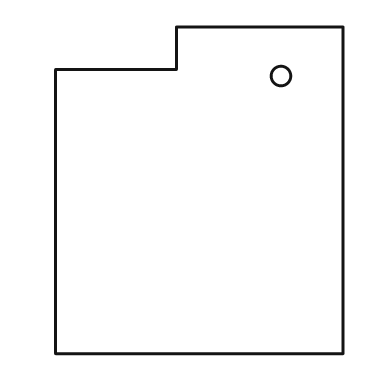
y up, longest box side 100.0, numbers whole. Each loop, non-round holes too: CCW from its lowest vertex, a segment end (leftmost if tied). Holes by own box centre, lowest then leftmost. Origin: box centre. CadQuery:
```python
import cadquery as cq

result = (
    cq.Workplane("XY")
    .moveTo(-44.0, -50.0)
    .lineTo(44.0, -50.0)
    .lineTo(44.0, 50.0)
    .lineTo(-7.0, 50.0)
    .lineTo(-7.0, 37.0)
    .lineTo(-44.0, 37.0)
    .close()
    .moveTo(25.0, 35.0)
    .circle(3.0)
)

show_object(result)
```